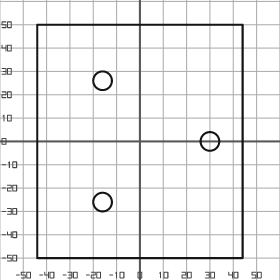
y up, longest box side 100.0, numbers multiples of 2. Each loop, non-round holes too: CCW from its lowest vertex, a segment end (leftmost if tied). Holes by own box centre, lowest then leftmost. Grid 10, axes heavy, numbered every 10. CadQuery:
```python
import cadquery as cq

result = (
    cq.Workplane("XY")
    .moveTo(-44.0, -50.0)
    .lineTo(44.0, -50.0)
    .lineTo(44.0, 50.0)
    .lineTo(-44.0, 50.0)
    .close()
    .moveTo(-16.0, -26.0)
    .circle(4.0)
    .moveTo(30.0, 0.0)
    .circle(4.0)
    .moveTo(-16.0, 26.0)
    .circle(4.0)
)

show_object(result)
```